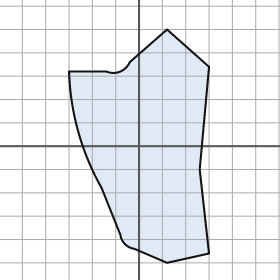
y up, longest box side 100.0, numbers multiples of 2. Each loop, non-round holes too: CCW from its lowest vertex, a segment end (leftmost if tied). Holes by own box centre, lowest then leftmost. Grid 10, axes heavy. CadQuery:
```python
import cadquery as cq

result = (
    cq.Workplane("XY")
    .moveTo(12.0, -50.0)
    .lineTo(30.0, -46.0)
    .lineTo(26.0, -10.0)
    .lineTo(30.0, 34.0)
    .lineTo(12.0, 50.0)
    .lineTo(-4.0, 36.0)
    .threePointArc((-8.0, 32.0), (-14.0, 32.0))
    .lineTo(-30.0, 32.0)
    .threePointArc((-26.0, 6.0), (-16.0, -18.0))
    .lineTo(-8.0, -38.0)
    .threePointArc((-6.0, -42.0), (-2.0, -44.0))
    .close()
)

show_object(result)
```